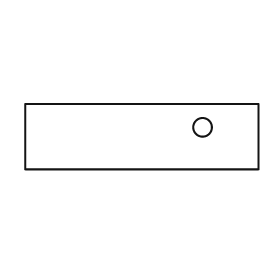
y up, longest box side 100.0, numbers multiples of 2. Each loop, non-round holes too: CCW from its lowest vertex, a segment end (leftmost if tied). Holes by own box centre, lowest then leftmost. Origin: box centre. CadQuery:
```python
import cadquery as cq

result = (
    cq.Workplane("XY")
    .moveTo(-50.0, -14.0)
    .lineTo(50.0, -14.0)
    .lineTo(50.0, 14.0)
    .lineTo(-50.0, 14.0)
    .close()
    .moveTo(26.0, 4.0)
    .circle(4.0)
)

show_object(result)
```